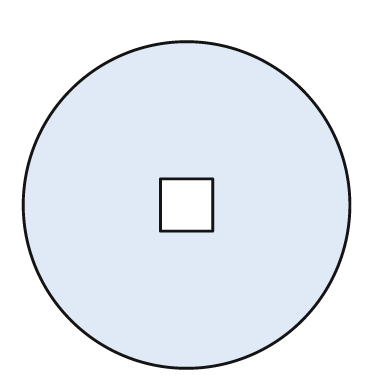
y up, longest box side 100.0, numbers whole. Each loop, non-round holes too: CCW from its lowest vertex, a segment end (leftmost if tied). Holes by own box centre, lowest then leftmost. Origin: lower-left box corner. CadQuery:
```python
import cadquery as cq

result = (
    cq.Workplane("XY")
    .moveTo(50.0, 50.0)
    .circle(50.0)
    .moveTo(42.0, 42.0)
    .lineTo(58.0, 42.0)
    .lineTo(58.0, 58.0)
    .lineTo(42.0, 58.0)
    .close()
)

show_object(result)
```